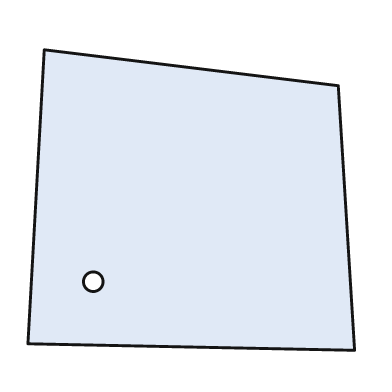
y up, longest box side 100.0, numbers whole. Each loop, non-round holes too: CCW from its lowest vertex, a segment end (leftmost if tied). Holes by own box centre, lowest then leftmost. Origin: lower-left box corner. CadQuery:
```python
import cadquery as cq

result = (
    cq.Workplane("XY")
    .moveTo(100.0, 0.0)
    .lineTo(95.0, 81.0)
    .lineTo(5.0, 92.0)
    .lineTo(0.0, 2.0)
    .close()
    .moveTo(20.0, 21.0)
    .circle(3.0)
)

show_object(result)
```